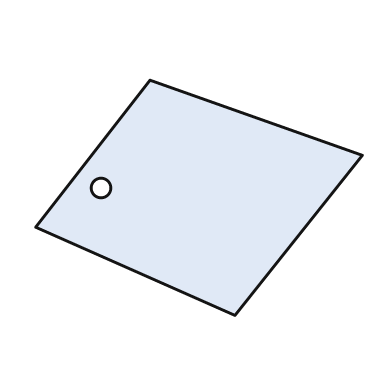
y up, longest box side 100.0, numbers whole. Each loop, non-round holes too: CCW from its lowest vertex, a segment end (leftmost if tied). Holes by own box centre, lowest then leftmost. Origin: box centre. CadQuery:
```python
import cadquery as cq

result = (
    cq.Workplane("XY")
    .moveTo(11.0, -36.0)
    .lineTo(50.0, 13.0)
    .lineTo(-15.0, 36.0)
    .lineTo(-50.0, -9.0)
    .close()
    .moveTo(-30.0, 3.0)
    .circle(3.0)
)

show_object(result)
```